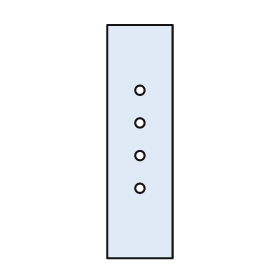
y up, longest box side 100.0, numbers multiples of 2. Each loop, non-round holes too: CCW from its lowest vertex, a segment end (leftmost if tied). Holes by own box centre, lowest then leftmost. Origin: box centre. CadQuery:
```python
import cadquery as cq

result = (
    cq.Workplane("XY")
    .moveTo(-14.0, -50.0)
    .lineTo(14.0, -50.0)
    .lineTo(14.0, 50.0)
    .lineTo(-14.0, 50.0)
    .close()
    .moveTo(0.0, -20.0)
    .circle(2.0)
    .moveTo(0.0, -6.0)
    .circle(2.0)
    .moveTo(0.0, 8.0)
    .circle(2.0)
    .moveTo(0.0, 22.0)
    .circle(2.0)
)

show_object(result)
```